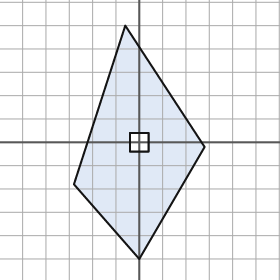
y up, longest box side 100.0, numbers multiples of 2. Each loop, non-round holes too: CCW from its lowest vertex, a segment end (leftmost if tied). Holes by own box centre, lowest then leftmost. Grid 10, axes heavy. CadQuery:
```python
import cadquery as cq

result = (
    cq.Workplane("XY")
    .moveTo(0.0, -50.0)
    .lineTo(28.0, -2.0)
    .lineTo(-6.0, 50.0)
    .lineTo(-28.0, -18.0)
    .close()
    .moveTo(-4.0, -4.0)
    .lineTo(4.0, -4.0)
    .lineTo(4.0, 4.0)
    .lineTo(-4.0, 4.0)
    .close()
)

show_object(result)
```